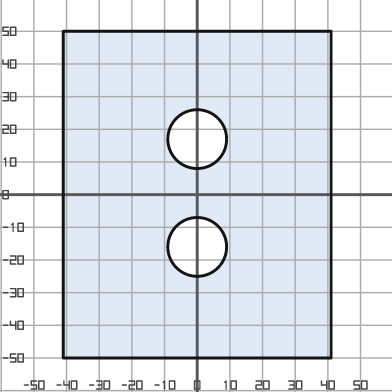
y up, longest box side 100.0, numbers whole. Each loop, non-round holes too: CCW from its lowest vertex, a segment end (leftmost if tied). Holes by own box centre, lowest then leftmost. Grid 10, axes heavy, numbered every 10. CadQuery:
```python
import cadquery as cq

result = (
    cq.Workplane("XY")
    .moveTo(-41.0, -50.0)
    .lineTo(41.0, -50.0)
    .lineTo(41.0, 50.0)
    .lineTo(-41.0, 50.0)
    .close()
    .moveTo(0.0, -16.0)
    .circle(9.0)
    .moveTo(0.0, 17.0)
    .circle(9.0)
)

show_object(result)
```